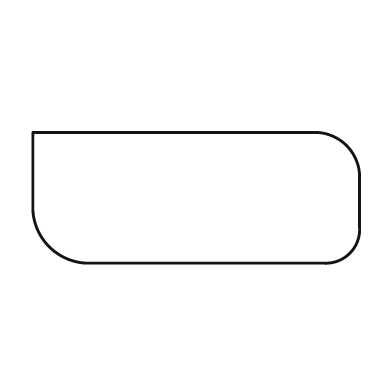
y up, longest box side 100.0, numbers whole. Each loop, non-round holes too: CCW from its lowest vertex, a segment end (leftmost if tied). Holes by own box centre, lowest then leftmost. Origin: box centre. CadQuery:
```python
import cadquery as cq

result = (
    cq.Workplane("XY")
    .moveTo(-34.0, -20.0)
    .lineTo(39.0, -20.0)
    .threePointArc((47.0, -17.0), (50.0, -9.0))
    .lineTo(50.0, 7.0)
    .threePointArc((46.0, 16.0), (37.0, 20.0))
    .lineTo(-50.0, 20.0)
    .lineTo(-50.0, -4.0)
    .threePointArc((-45.0, -15.0), (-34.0, -20.0))
    .close()
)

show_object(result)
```